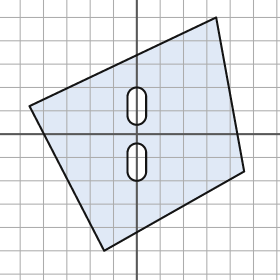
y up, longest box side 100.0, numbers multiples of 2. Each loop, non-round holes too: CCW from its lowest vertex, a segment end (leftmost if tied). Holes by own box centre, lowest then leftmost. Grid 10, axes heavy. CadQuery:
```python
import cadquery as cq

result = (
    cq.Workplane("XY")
    .moveTo(-14.0, -50.0)
    .lineTo(46.0, -16.0)
    .lineTo(34.0, 50.0)
    .lineTo(-46.0, 12.0)
    .close()
    .moveTo(-4.0, -16.0)
    .threePointArc((0.0, -20.0), (4.0, -16.0))
    .lineTo(4.0, -8.0)
    .threePointArc((0.0, -4.0), (-4.0, -8.0))
    .close()
    .moveTo(-4.0, 8.0)
    .threePointArc((0.0, 4.0), (4.0, 8.0))
    .lineTo(4.0, 16.0)
    .threePointArc((0.0, 20.0), (-4.0, 16.0))
    .close()
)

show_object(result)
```